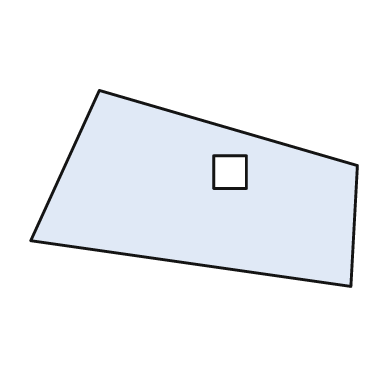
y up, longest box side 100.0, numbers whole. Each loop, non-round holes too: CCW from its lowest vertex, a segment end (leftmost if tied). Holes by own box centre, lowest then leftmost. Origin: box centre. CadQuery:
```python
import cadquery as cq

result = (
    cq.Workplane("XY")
    .moveTo(48.0, -30.0)
    .lineTo(50.0, 7.0)
    .lineTo(-29.0, 30.0)
    .lineTo(-50.0, -16.0)
    .close()
    .moveTo(6.0, 0.0)
    .lineTo(16.0, 0.0)
    .lineTo(16.0, 10.0)
    .lineTo(6.0, 10.0)
    .close()
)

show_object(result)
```